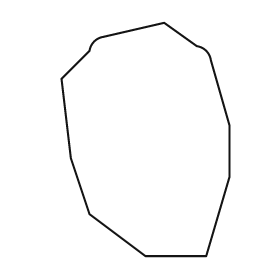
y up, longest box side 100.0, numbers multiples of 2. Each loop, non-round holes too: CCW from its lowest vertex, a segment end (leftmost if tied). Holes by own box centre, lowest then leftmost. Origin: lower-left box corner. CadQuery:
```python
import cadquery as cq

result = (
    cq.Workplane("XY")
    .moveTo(36.0, 0.0)
    .lineTo(62.0, 0.0)
    .lineTo(72.0, 34.0)
    .lineTo(72.0, 56.0)
    .lineTo(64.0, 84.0)
    .threePointArc((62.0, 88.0), (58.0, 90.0))
    .lineTo(44.0, 100.0)
    .lineTo(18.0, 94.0)
    .threePointArc((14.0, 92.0), (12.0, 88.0))
    .lineTo(0.0, 76.0)
    .lineTo(4.0, 42.0)
    .lineTo(12.0, 18.0)
    .close()
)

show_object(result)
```